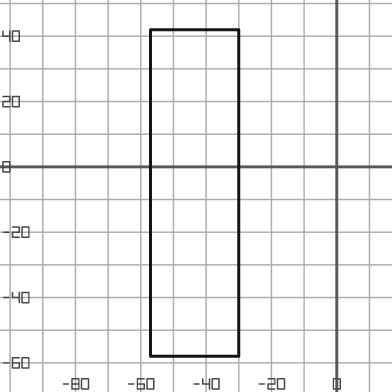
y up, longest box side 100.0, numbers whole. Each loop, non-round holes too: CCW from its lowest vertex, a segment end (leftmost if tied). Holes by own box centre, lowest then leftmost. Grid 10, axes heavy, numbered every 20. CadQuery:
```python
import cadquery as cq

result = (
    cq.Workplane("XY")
    .moveTo(-57.0, -58.0)
    .lineTo(-30.0, -58.0)
    .lineTo(-30.0, 42.0)
    .lineTo(-57.0, 42.0)
    .close()
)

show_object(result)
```